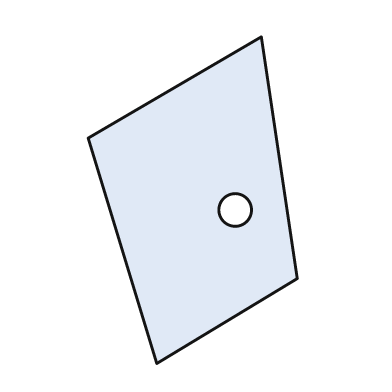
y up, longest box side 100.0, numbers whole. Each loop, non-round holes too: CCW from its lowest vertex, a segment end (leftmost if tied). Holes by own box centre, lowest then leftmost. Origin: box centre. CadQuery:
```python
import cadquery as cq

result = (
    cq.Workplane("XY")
    .moveTo(-11.0, -50.0)
    .lineTo(32.0, -24.0)
    .lineTo(21.0, 50.0)
    .lineTo(-32.0, 19.0)
    .close()
    .moveTo(13.0, -3.0)
    .circle(5.0)
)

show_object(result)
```